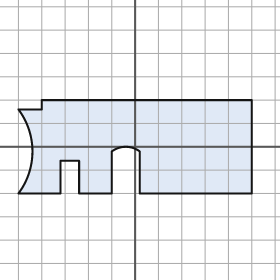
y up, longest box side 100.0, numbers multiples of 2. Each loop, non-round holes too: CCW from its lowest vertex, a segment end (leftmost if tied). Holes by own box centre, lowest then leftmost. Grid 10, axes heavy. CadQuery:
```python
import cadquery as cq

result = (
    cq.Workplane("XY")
    .moveTo(-50.0, -20.0)
    .lineTo(-32.0, -20.0)
    .lineTo(-32.0, -6.0)
    .lineTo(-24.0, -6.0)
    .lineTo(-24.0, -20.0)
    .lineTo(-10.0, -20.0)
    .lineTo(-10.0, -2.0)
    .threePointArc((-4.0, 0.0), (2.0, -2.0))
    .lineTo(2.0, -20.0)
    .lineTo(50.0, -20.0)
    .lineTo(50.0, 20.0)
    .lineTo(-40.0, 20.0)
    .lineTo(-40.0, 16.0)
    .lineTo(-50.0, 16.0)
    .threePointArc((-44.0, -2.0), (-50.0, -20.0))
    .close()
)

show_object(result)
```